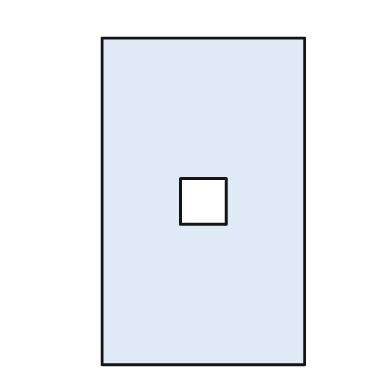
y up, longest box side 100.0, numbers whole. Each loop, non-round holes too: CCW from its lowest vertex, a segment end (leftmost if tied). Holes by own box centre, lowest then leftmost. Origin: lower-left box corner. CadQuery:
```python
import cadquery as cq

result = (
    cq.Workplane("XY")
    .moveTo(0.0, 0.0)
    .lineTo(62.0, 0.0)
    .lineTo(62.0, 100.0)
    .lineTo(0.0, 100.0)
    .close()
    .moveTo(24.0, 43.0)
    .lineTo(38.0, 43.0)
    .lineTo(38.0, 57.0)
    .lineTo(24.0, 57.0)
    .close()
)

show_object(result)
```